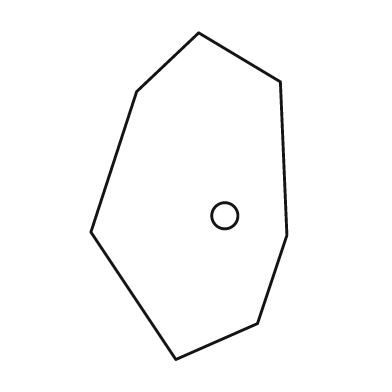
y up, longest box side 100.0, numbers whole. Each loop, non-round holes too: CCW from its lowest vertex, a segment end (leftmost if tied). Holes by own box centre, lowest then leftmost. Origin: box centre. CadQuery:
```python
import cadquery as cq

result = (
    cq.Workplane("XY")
    .moveTo(-4.0, -50.0)
    .lineTo(21.0, -39.0)
    .lineTo(30.0, -12.0)
    .lineTo(28.0, 35.0)
    .lineTo(3.0, 50.0)
    .lineTo(-16.0, 32.0)
    .lineTo(-30.0, -11.0)
    .close()
    .moveTo(11.0, -6.0)
    .circle(4.0)
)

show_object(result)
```